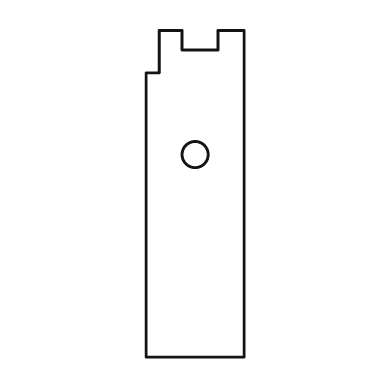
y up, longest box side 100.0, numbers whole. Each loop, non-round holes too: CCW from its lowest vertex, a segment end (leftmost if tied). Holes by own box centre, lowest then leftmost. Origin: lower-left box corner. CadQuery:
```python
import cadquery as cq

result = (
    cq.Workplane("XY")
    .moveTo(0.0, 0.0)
    .lineTo(30.0, 0.0)
    .lineTo(30.0, 100.0)
    .lineTo(22.0, 100.0)
    .lineTo(22.0, 94.0)
    .lineTo(11.0, 94.0)
    .lineTo(11.0, 100.0)
    .lineTo(4.0, 100.0)
    .lineTo(4.0, 87.0)
    .lineTo(0.0, 87.0)
    .close()
    .moveTo(15.0, 62.0)
    .circle(4.0)
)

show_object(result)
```